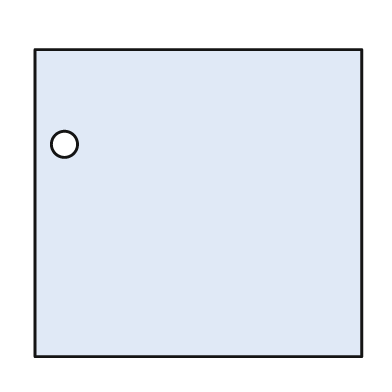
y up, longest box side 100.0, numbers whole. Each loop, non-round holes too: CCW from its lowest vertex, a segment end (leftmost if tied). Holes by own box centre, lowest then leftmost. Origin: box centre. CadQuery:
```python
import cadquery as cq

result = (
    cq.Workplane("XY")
    .moveTo(-50.0, -47.0)
    .lineTo(50.0, -47.0)
    .lineTo(50.0, 47.0)
    .lineTo(-50.0, 47.0)
    .close()
    .moveTo(-41.0, 18.0)
    .circle(4.0)
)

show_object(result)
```